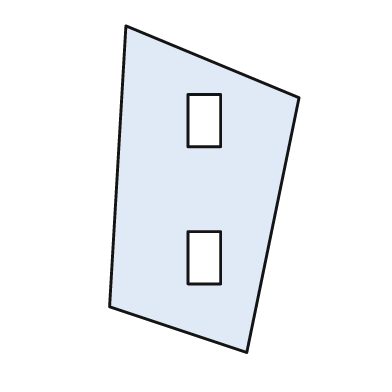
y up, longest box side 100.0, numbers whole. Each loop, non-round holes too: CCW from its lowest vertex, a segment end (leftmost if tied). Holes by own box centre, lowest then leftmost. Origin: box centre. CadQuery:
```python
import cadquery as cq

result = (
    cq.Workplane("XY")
    .moveTo(13.0, -50.0)
    .lineTo(29.0, 28.0)
    .lineTo(-24.0, 50.0)
    .lineTo(-29.0, -36.0)
    .close()
    .moveTo(-5.0, -29.0)
    .lineTo(5.0, -29.0)
    .lineTo(5.0, -13.0)
    .lineTo(-5.0, -13.0)
    .close()
    .moveTo(-5.0, 13.0)
    .lineTo(5.0, 13.0)
    .lineTo(5.0, 29.0)
    .lineTo(-5.0, 29.0)
    .close()
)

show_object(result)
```